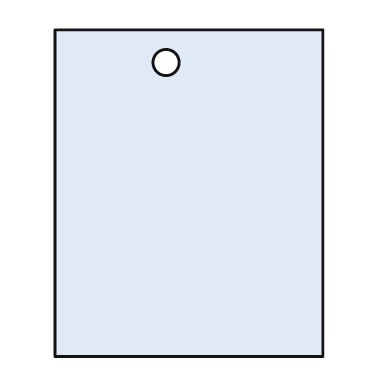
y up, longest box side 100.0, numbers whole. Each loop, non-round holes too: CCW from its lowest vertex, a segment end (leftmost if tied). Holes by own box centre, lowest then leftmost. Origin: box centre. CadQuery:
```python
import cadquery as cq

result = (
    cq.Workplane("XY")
    .moveTo(-41.0, -50.0)
    .lineTo(41.0, -50.0)
    .lineTo(41.0, 50.0)
    .lineTo(-41.0, 50.0)
    .close()
    .moveTo(-7.0, 40.0)
    .circle(4.0)
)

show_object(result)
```